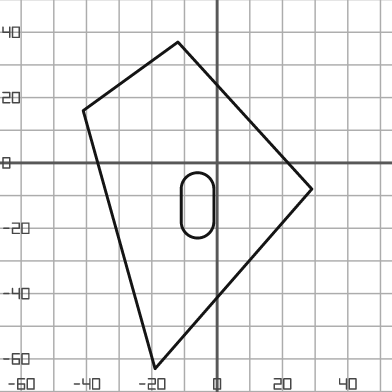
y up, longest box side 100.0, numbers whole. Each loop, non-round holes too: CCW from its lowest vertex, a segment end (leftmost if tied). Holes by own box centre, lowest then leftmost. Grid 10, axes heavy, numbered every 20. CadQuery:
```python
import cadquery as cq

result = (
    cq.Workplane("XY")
    .moveTo(-19.0, -63.0)
    .lineTo(29.0, -8.0)
    .lineTo(-12.0, 37.0)
    .lineTo(-41.0, 16.0)
    .close()
    .moveTo(-11.0, -18.0)
    .threePointArc((-6.0, -23.0), (-1.0, -18.0))
    .lineTo(-1.0, -8.0)
    .threePointArc((-6.0, -3.0), (-11.0, -8.0))
    .close()
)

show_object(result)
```